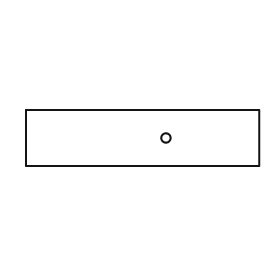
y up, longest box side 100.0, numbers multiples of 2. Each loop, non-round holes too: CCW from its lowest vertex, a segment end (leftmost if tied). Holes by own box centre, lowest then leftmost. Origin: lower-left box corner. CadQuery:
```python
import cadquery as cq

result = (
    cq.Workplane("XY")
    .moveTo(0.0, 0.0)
    .lineTo(100.0, 0.0)
    .lineTo(100.0, 24.0)
    .lineTo(0.0, 24.0)
    .close()
    .moveTo(60.0, 12.0)
    .circle(2.0)
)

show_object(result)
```